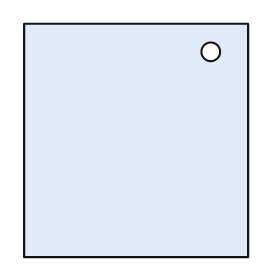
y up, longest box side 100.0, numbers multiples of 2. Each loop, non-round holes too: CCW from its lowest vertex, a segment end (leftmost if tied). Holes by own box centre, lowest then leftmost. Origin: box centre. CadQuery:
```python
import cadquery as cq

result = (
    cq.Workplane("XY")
    .moveTo(-48.0, -50.0)
    .lineTo(48.0, -50.0)
    .lineTo(48.0, 50.0)
    .lineTo(-48.0, 50.0)
    .close()
    .moveTo(32.0, 38.0)
    .circle(4.0)
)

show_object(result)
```